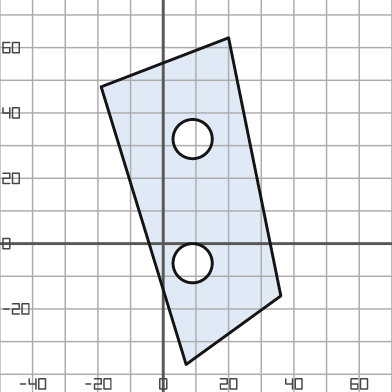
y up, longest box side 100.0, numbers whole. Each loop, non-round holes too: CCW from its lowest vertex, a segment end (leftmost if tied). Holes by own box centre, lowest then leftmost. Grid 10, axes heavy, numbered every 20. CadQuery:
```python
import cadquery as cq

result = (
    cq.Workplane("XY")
    .moveTo(7.0, -37.0)
    .lineTo(36.0, -16.0)
    .lineTo(20.0, 63.0)
    .lineTo(-19.0, 48.0)
    .close()
    .moveTo(9.0, -6.0)
    .circle(6.0)
    .moveTo(9.0, 32.0)
    .circle(6.0)
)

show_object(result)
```